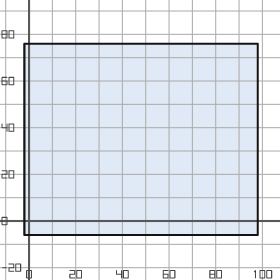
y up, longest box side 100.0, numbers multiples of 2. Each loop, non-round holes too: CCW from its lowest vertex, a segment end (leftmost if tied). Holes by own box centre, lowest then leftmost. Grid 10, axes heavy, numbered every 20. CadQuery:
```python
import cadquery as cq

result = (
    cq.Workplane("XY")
    .moveTo(-2.0, -6.0)
    .lineTo(98.0, -6.0)
    .lineTo(98.0, 76.0)
    .lineTo(-2.0, 76.0)
    .close()
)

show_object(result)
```